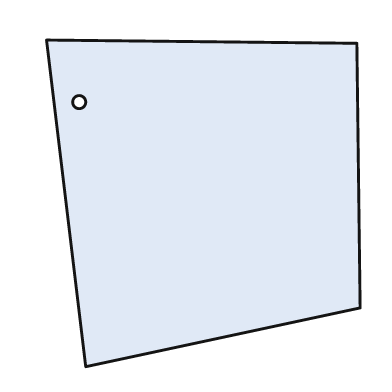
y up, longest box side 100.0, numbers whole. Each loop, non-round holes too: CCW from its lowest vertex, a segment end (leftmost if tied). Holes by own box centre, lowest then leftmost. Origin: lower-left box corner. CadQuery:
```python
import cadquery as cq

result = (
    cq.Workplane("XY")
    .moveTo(12.0, 0.0)
    .lineTo(96.0, 18.0)
    .lineTo(95.0, 99.0)
    .lineTo(0.0, 100.0)
    .close()
    .moveTo(10.0, 81.0)
    .circle(2.0)
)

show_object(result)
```